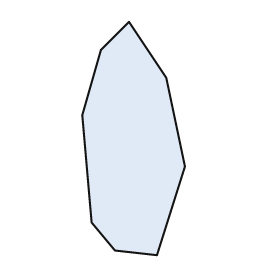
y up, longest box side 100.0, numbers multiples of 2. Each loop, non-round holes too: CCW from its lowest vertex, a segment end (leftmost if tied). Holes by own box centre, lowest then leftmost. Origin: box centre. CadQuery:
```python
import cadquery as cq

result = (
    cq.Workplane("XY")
    .moveTo(10.0, -50.0)
    .lineTo(22.0, -12.0)
    .lineTo(14.0, 26.0)
    .lineTo(-2.0, 50.0)
    .lineTo(-14.0, 38.0)
    .lineTo(-22.0, 10.0)
    .lineTo(-18.0, -36.0)
    .lineTo(-8.0, -48.0)
    .close()
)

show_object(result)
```